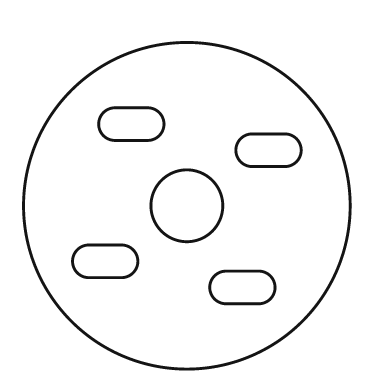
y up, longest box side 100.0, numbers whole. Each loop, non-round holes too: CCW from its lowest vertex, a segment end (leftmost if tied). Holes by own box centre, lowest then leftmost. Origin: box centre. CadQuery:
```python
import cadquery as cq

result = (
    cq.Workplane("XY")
    .moveTo(0.0, 0.0)
    .circle(50.0)
    .moveTo(12.0, -30.0)
    .lineTo(22.0, -30.0)
    .threePointArc((27.0, -25.0), (22.0, -20.0))
    .lineTo(12.0, -20.0)
    .threePointArc((7.0, -25.0), (12.0, -30.0))
    .close()
    .moveTo(-30.0, -22.0)
    .lineTo(-20.0, -22.0)
    .threePointArc((-15.0, -17.0), (-20.0, -12.0))
    .lineTo(-30.0, -12.0)
    .threePointArc((-35.0, -17.0), (-30.0, -22.0))
    .close()
    .moveTo(0.0, 0.0)
    .circle(11.0)
    .moveTo(20.0, 12.0)
    .lineTo(30.0, 12.0)
    .threePointArc((35.0, 17.0), (30.0, 22.0))
    .lineTo(20.0, 22.0)
    .threePointArc((15.0, 17.0), (20.0, 12.0))
    .close()
    .moveTo(-22.0, 20.0)
    .lineTo(-12.0, 20.0)
    .threePointArc((-7.0, 25.0), (-12.0, 30.0))
    .lineTo(-22.0, 30.0)
    .threePointArc((-27.0, 25.0), (-22.0, 20.0))
    .close()
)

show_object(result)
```